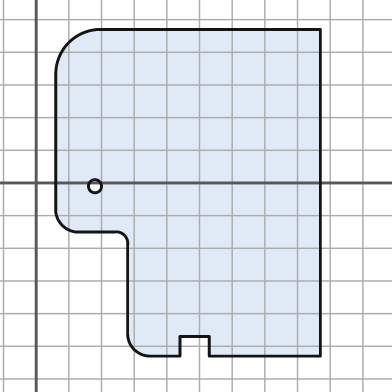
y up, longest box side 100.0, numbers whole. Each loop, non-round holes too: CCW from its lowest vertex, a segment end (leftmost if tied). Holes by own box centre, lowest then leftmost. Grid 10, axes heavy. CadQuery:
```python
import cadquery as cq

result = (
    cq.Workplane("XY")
    .moveTo(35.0, -53.0)
    .lineTo(44.0, -53.0)
    .lineTo(44.0, -47.0)
    .lineTo(53.0, -47.0)
    .lineTo(53.0, -53.0)
    .lineTo(87.0, -53.0)
    .lineTo(87.0, 47.0)
    .lineTo(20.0, 47.0)
    .threePointArc((10.0, 43.0), (6.0, 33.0))
    .lineTo(6.0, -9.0)
    .threePointArc((8.0, -13.0), (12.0, -15.0))
    .lineTo(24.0, -15.0)
    .threePointArc((27.0, -16.0), (28.0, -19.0))
    .lineTo(28.0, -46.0)
    .threePointArc((30.0, -51.0), (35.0, -53.0))
    .close()
    .moveTo(18.0, -1.0)
    .circle(2.0)
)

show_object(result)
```